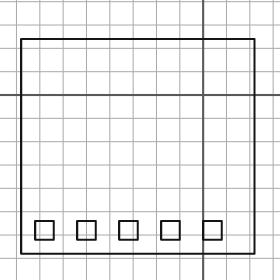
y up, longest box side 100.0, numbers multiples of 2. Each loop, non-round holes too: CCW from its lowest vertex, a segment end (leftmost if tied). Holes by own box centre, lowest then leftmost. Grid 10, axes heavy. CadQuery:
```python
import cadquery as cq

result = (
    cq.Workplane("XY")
    .moveTo(-78.0, -68.0)
    .lineTo(22.0, -68.0)
    .lineTo(22.0, 24.0)
    .lineTo(-78.0, 24.0)
    .close()
    .moveTo(-72.0, -62.0)
    .lineTo(-64.0, -62.0)
    .lineTo(-64.0, -54.0)
    .lineTo(-72.0, -54.0)
    .close()
    .moveTo(-54.0, -62.0)
    .lineTo(-46.0, -62.0)
    .lineTo(-46.0, -54.0)
    .lineTo(-54.0, -54.0)
    .close()
    .moveTo(-36.0, -62.0)
    .lineTo(-28.0, -62.0)
    .lineTo(-28.0, -54.0)
    .lineTo(-36.0, -54.0)
    .close()
    .moveTo(-18.0, -62.0)
    .lineTo(-10.0, -62.0)
    .lineTo(-10.0, -54.0)
    .lineTo(-18.0, -54.0)
    .close()
    .moveTo(0.0, -62.0)
    .lineTo(8.0, -62.0)
    .lineTo(8.0, -54.0)
    .lineTo(0.0, -54.0)
    .close()
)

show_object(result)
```